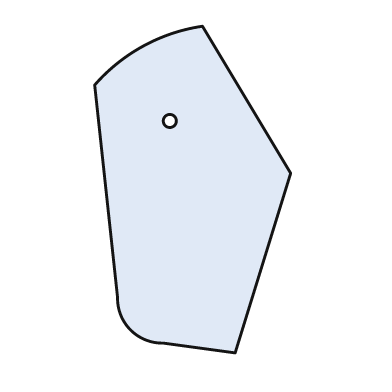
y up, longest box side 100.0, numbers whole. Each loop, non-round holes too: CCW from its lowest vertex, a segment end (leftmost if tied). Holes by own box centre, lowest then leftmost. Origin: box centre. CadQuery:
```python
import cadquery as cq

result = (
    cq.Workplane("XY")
    .moveTo(13.0, -50.0)
    .lineTo(30.0, 5.0)
    .lineTo(3.0, 50.0)
    .threePointArc((-15.0, 44.0), (-30.0, 32.0))
    .lineTo(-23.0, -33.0)
    .threePointArc((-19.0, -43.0), (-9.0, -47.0))
    .close()
    .moveTo(-7.0, 21.0)
    .circle(2.0)
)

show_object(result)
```